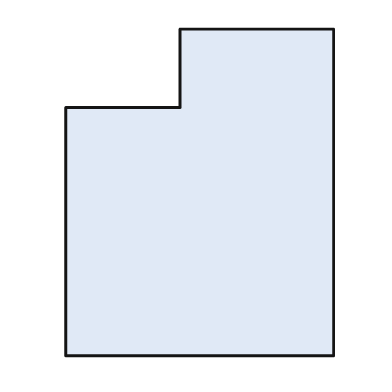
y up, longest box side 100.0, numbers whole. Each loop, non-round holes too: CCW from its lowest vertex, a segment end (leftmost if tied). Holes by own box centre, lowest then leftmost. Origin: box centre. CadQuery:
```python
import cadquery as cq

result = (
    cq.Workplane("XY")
    .moveTo(-41.0, -50.0)
    .lineTo(41.0, -50.0)
    .lineTo(41.0, 50.0)
    .lineTo(-6.0, 50.0)
    .lineTo(-6.0, 26.0)
    .lineTo(-41.0, 26.0)
    .close()
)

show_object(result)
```